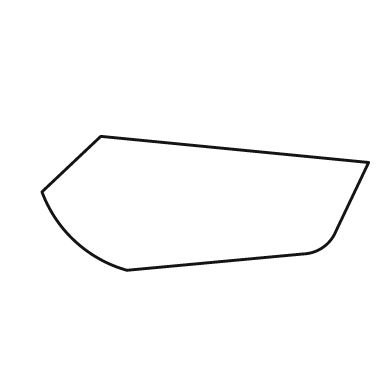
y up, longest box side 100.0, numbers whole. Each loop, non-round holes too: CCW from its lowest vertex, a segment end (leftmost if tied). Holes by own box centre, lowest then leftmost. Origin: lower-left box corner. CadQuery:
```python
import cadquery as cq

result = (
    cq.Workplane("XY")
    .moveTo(26.0, 0.0)
    .lineTo(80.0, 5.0)
    .threePointArc((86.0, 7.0), (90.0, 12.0))
    .lineTo(100.0, 33.0)
    .lineTo(18.0, 41.0)
    .lineTo(0.0, 24.0)
    .threePointArc((10.0, 9.0), (26.0, 0.0))
    .close()
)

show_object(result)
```